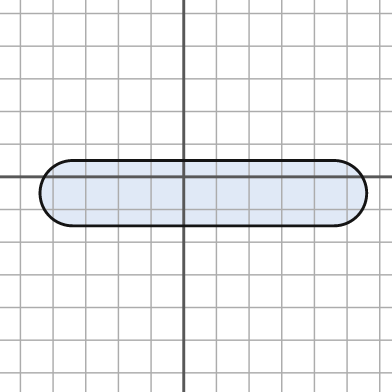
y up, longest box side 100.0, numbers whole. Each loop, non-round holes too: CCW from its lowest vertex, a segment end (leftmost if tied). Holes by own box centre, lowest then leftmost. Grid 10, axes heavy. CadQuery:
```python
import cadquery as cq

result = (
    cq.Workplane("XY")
    .moveTo(-34.0, -15.0)
    .lineTo(46.0, -15.0)
    .threePointArc((56.0, -5.0), (46.0, 5.0))
    .lineTo(-34.0, 5.0)
    .threePointArc((-44.0, -5.0), (-34.0, -15.0))
    .close()
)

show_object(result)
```